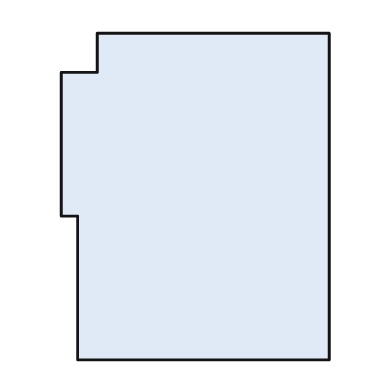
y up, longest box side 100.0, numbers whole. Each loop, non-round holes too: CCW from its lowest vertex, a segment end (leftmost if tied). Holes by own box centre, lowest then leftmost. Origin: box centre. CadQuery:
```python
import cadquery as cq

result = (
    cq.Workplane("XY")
    .moveTo(-36.0, -50.0)
    .lineTo(41.0, -50.0)
    .lineTo(41.0, 50.0)
    .lineTo(-30.0, 50.0)
    .lineTo(-30.0, 38.0)
    .lineTo(-41.0, 38.0)
    .lineTo(-41.0, -6.0)
    .lineTo(-36.0, -6.0)
    .close()
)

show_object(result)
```